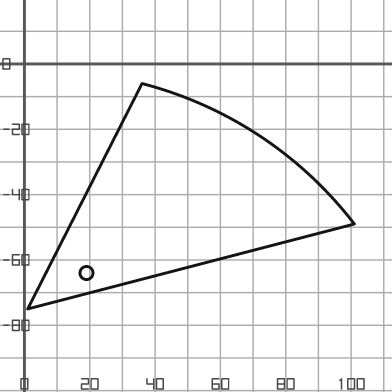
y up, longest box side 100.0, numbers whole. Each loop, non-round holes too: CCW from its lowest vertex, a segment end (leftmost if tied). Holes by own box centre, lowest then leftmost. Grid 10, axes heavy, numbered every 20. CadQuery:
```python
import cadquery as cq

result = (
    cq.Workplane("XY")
    .moveTo(1.0, -75.0)
    .lineTo(101.0, -49.0)
    .threePointArc((72.0, -22.0), (36.0, -6.0))
    .close()
    .moveTo(19.0, -64.0)
    .circle(2.0)
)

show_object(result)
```